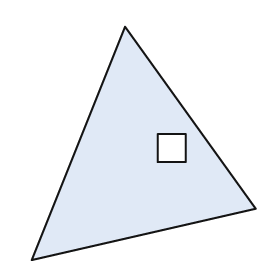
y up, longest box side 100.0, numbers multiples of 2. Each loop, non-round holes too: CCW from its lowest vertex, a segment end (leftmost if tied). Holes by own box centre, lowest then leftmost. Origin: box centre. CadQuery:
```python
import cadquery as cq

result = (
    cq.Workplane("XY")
    .moveTo(-48.0, -50.0)
    .lineTo(48.0, -28.0)
    .lineTo(-8.0, 50.0)
    .close()
    .moveTo(6.0, -8.0)
    .lineTo(18.0, -8.0)
    .lineTo(18.0, 4.0)
    .lineTo(6.0, 4.0)
    .close()
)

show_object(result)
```